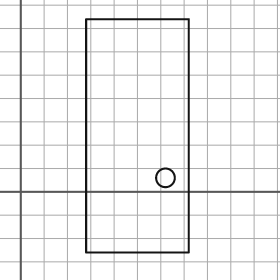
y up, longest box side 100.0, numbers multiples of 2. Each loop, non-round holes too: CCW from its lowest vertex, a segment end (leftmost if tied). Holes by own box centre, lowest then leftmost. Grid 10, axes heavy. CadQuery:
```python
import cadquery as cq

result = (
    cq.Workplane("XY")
    .moveTo(28.0, -26.0)
    .lineTo(72.0, -26.0)
    .lineTo(72.0, 74.0)
    .lineTo(28.0, 74.0)
    .close()
    .moveTo(62.0, 6.0)
    .circle(4.0)
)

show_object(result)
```